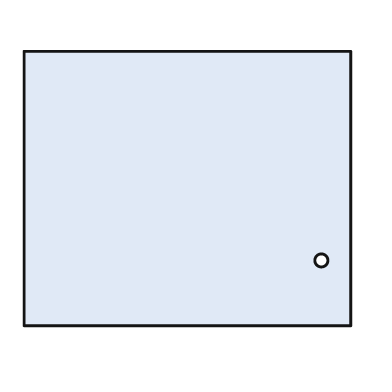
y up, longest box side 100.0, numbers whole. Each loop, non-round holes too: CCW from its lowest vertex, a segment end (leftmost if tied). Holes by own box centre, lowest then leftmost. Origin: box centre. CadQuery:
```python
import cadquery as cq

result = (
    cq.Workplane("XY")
    .moveTo(-50.0, -42.0)
    .lineTo(50.0, -42.0)
    .lineTo(50.0, 42.0)
    .lineTo(-50.0, 42.0)
    .close()
    .moveTo(41.0, -22.0)
    .circle(2.0)
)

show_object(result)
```